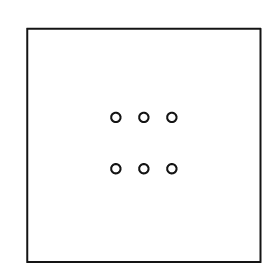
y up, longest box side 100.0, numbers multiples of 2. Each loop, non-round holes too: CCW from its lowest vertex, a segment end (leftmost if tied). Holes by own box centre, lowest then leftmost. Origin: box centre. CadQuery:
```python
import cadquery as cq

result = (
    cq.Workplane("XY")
    .moveTo(-50.0, -50.0)
    .lineTo(50.0, -50.0)
    .lineTo(50.0, 50.0)
    .lineTo(-50.0, 50.0)
    .close()
    .moveTo(-12.0, -10.0)
    .circle(2.0)
    .moveTo(0.0, -10.0)
    .circle(2.0)
    .moveTo(12.0, -10.0)
    .circle(2.0)
    .moveTo(-12.0, 12.0)
    .circle(2.0)
    .moveTo(0.0, 12.0)
    .circle(2.0)
    .moveTo(12.0, 12.0)
    .circle(2.0)
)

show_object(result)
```